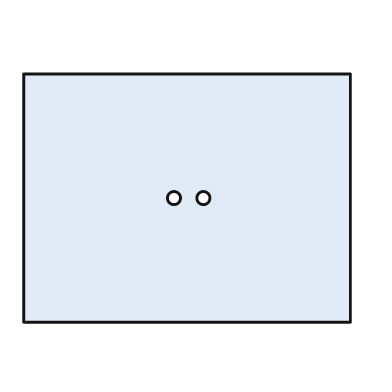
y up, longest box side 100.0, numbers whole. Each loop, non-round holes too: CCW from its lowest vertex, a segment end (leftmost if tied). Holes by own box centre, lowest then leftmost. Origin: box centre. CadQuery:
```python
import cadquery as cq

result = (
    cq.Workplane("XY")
    .moveTo(-50.0, -38.0)
    .lineTo(50.0, -38.0)
    .lineTo(50.0, 38.0)
    .lineTo(-50.0, 38.0)
    .close()
    .moveTo(-4.0, 0.0)
    .circle(2.0)
    .moveTo(5.0, 0.0)
    .circle(2.0)
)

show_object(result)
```